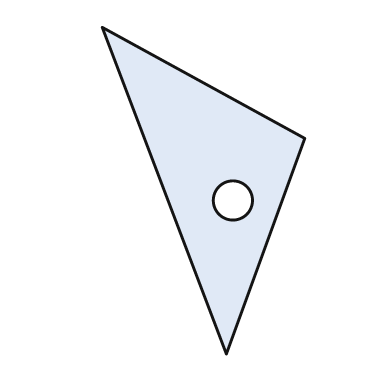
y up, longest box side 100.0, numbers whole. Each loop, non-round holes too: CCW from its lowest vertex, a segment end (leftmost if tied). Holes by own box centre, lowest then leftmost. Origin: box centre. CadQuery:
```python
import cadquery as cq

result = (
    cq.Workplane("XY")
    .moveTo(7.0, -50.0)
    .lineTo(31.0, 16.0)
    .lineTo(-31.0, 50.0)
    .close()
    .moveTo(9.0, -3.0)
    .circle(6.0)
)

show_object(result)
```